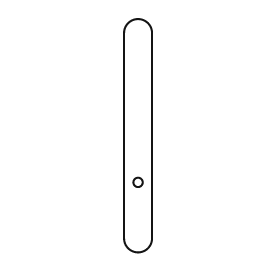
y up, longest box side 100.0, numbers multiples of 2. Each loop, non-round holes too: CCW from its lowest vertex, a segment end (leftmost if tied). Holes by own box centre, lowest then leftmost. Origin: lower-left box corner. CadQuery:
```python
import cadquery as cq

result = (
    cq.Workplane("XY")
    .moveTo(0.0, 6.0)
    .threePointArc((6.0, 0.0), (12.0, 6.0))
    .lineTo(12.0, 94.0)
    .threePointArc((6.0, 100.0), (0.0, 94.0))
    .close()
    .moveTo(6.0, 30.0)
    .circle(2.0)
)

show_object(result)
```